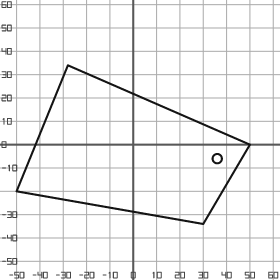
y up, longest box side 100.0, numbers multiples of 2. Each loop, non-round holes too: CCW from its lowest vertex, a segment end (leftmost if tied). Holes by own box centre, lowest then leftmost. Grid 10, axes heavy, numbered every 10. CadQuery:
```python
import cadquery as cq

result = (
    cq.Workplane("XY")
    .moveTo(30.0, -34.0)
    .lineTo(50.0, 0.0)
    .lineTo(-28.0, 34.0)
    .lineTo(-50.0, -20.0)
    .close()
    .moveTo(36.0, -6.0)
    .circle(2.0)
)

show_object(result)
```